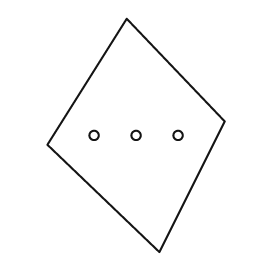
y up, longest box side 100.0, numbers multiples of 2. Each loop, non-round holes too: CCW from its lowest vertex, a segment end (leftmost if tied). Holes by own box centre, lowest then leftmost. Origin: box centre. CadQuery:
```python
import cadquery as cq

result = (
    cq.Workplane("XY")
    .moveTo(10.0, -50.0)
    .lineTo(38.0, 6.0)
    .lineTo(-4.0, 50.0)
    .lineTo(-38.0, -4.0)
    .close()
    .moveTo(-18.0, 0.0)
    .circle(2.0)
    .moveTo(0.0, 0.0)
    .circle(2.0)
    .moveTo(18.0, 0.0)
    .circle(2.0)
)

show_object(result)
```